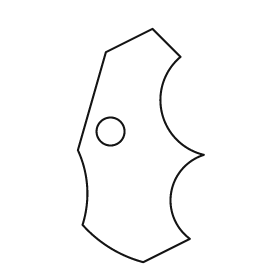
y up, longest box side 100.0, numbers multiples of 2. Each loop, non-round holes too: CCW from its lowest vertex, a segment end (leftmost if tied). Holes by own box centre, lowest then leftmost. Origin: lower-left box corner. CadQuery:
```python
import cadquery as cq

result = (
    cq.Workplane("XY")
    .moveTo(28.0, 0.0)
    .lineTo(48.0, 10.0)
    .threePointArc((40.0, 30.0), (54.0, 46.0))
    .threePointArc((36.0, 64.0), (44.0, 88.0))
    .lineTo(32.0, 100.0)
    .lineTo(12.0, 90.0)
    .lineTo(0.0, 48.0)
    .threePointArc((4.0, 32.0), (2.0, 16.0))
    .threePointArc((14.0, 6.0), (28.0, 0.0))
    .close()
    .moveTo(14.0, 56.0)
    .circle(6.0)
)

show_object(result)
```